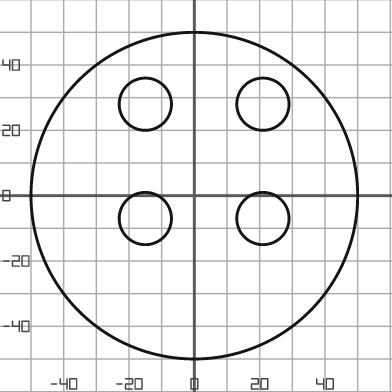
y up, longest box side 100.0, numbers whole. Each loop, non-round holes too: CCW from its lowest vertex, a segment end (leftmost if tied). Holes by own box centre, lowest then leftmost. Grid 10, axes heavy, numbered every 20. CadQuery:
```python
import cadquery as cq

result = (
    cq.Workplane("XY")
    .moveTo(0.0, 0.0)
    .circle(50.0)
    .moveTo(-15.0, -7.0)
    .circle(8.0)
    .moveTo(21.0, -7.0)
    .circle(8.0)
    .moveTo(-15.0, 28.0)
    .circle(8.0)
    .moveTo(21.0, 28.0)
    .circle(8.0)
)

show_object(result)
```